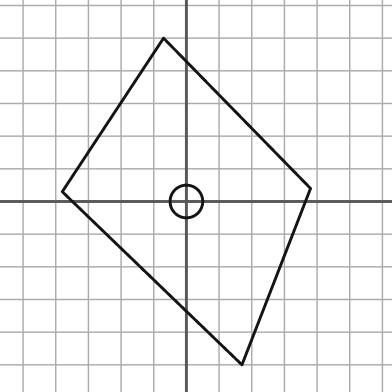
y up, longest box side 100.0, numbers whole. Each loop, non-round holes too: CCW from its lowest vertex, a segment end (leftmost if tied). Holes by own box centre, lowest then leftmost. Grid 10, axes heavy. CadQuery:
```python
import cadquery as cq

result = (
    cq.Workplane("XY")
    .moveTo(17.0, -50.0)
    .lineTo(38.0, 4.0)
    .lineTo(-7.0, 50.0)
    .lineTo(-38.0, 3.0)
    .close()
    .moveTo(0.0, 0.0)
    .circle(5.0)
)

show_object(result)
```